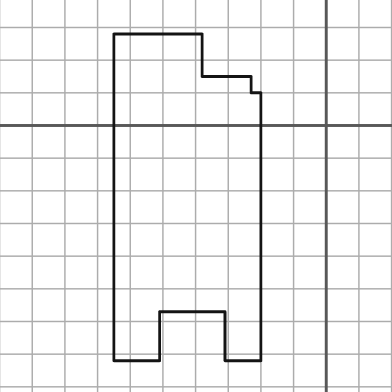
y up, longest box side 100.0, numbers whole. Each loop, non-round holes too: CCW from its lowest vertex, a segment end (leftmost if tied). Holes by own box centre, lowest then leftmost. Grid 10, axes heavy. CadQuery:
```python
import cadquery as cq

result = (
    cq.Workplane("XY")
    .moveTo(-65.0, -72.0)
    .lineTo(-51.0, -72.0)
    .lineTo(-51.0, -57.0)
    .lineTo(-31.0, -57.0)
    .lineTo(-31.0, -72.0)
    .lineTo(-20.0, -72.0)
    .lineTo(-20.0, 10.0)
    .lineTo(-23.0, 10.0)
    .lineTo(-23.0, 15.0)
    .lineTo(-38.0, 15.0)
    .lineTo(-38.0, 28.0)
    .lineTo(-65.0, 28.0)
    .close()
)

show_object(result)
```